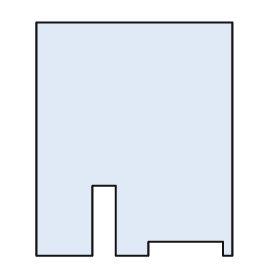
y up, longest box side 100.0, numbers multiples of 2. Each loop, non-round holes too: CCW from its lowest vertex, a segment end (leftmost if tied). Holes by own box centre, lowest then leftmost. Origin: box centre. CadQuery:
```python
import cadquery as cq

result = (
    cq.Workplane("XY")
    .moveTo(-42.0, -50.0)
    .lineTo(-18.0, -50.0)
    .lineTo(-18.0, -20.0)
    .lineTo(-8.0, -20.0)
    .lineTo(-8.0, -50.0)
    .lineTo(6.0, -50.0)
    .lineTo(6.0, -44.0)
    .lineTo(38.0, -44.0)
    .lineTo(38.0, -50.0)
    .lineTo(42.0, -50.0)
    .lineTo(42.0, 50.0)
    .lineTo(-42.0, 50.0)
    .close()
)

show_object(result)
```